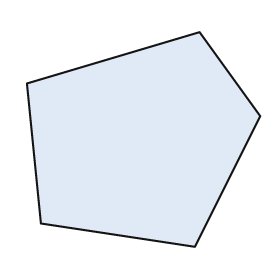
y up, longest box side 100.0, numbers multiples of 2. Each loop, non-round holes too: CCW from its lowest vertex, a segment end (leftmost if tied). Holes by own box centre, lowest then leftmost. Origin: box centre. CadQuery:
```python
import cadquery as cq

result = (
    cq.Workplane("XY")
    .moveTo(22.0, -46.0)
    .lineTo(50.0, 10.0)
    .lineTo(24.0, 46.0)
    .lineTo(-50.0, 24.0)
    .lineTo(-44.0, -36.0)
    .close()
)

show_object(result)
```